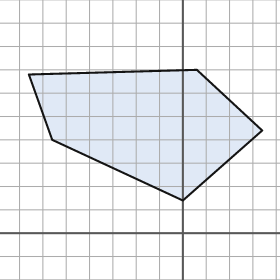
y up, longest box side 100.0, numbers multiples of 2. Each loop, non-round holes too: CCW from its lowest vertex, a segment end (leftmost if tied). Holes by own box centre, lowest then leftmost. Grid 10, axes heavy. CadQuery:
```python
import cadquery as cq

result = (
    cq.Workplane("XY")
    .moveTo(0.0, 14.0)
    .lineTo(34.0, 44.0)
    .lineTo(6.0, 70.0)
    .lineTo(-66.0, 68.0)
    .lineTo(-56.0, 40.0)
    .close()
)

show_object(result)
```